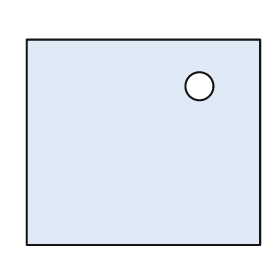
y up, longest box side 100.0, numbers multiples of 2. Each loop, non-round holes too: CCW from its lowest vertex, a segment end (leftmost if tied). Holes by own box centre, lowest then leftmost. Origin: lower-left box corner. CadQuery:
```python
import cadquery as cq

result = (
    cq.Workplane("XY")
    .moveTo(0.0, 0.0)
    .lineTo(100.0, 0.0)
    .lineTo(100.0, 88.0)
    .lineTo(0.0, 88.0)
    .close()
    .moveTo(74.0, 68.0)
    .circle(6.0)
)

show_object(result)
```